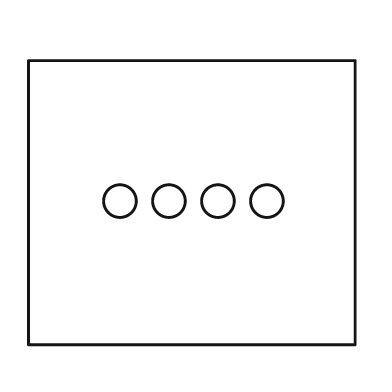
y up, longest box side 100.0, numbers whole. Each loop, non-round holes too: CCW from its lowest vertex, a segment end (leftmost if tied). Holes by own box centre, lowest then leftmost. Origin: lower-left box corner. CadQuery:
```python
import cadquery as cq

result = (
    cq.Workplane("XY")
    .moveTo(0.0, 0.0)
    .lineTo(100.0, 0.0)
    .lineTo(100.0, 87.0)
    .lineTo(0.0, 87.0)
    .close()
    .moveTo(28.0, 44.0)
    .circle(5.0)
    .moveTo(43.0, 44.0)
    .circle(5.0)
    .moveTo(58.0, 44.0)
    .circle(5.0)
    .moveTo(73.0, 44.0)
    .circle(5.0)
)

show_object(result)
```